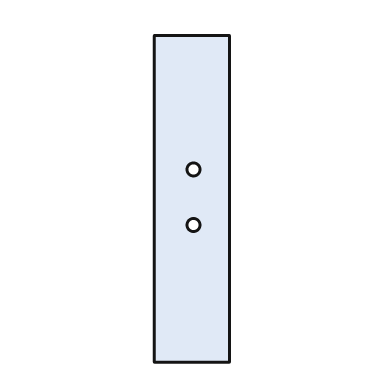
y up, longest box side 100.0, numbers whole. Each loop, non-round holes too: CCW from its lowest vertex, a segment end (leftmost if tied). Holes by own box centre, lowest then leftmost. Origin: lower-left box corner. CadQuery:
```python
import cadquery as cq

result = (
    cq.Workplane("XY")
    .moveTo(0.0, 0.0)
    .lineTo(23.0, 0.0)
    .lineTo(23.0, 100.0)
    .lineTo(0.0, 100.0)
    .close()
    .moveTo(12.0, 42.0)
    .circle(2.0)
    .moveTo(12.0, 59.0)
    .circle(2.0)
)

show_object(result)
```